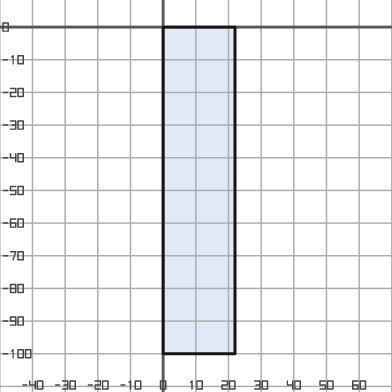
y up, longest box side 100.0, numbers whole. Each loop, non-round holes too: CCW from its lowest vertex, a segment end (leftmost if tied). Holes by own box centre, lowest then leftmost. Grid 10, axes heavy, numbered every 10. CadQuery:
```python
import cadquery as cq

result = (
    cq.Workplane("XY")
    .moveTo(0.0, -100.0)
    .lineTo(22.0, -100.0)
    .lineTo(22.0, 0.0)
    .lineTo(0.0, 0.0)
    .close()
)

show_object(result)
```